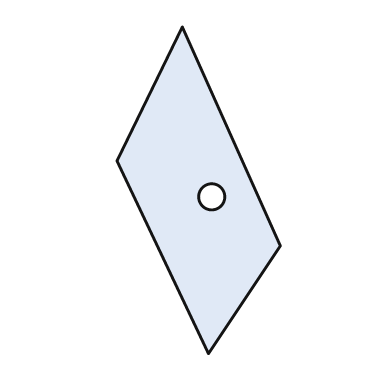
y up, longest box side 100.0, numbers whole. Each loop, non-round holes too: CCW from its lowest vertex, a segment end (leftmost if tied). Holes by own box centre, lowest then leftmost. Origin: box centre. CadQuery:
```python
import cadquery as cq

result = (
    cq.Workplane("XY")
    .moveTo(3.0, -50.0)
    .lineTo(25.0, -17.0)
    .lineTo(-5.0, 50.0)
    .lineTo(-25.0, 9.0)
    .close()
    .moveTo(4.0, -2.0)
    .circle(4.0)
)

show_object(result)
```